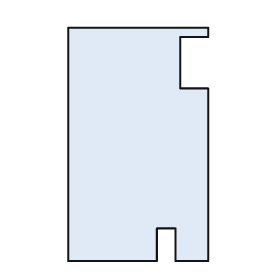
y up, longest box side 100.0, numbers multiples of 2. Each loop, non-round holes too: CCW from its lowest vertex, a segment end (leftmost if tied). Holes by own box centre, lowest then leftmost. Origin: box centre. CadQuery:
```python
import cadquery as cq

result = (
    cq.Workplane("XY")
    .moveTo(-30.0, -50.0)
    .lineTo(8.0, -50.0)
    .lineTo(8.0, -36.0)
    .lineTo(16.0, -36.0)
    .lineTo(16.0, -50.0)
    .lineTo(30.0, -50.0)
    .lineTo(30.0, 24.0)
    .lineTo(18.0, 24.0)
    .lineTo(18.0, 46.0)
    .lineTo(30.0, 46.0)
    .lineTo(30.0, 50.0)
    .lineTo(-30.0, 50.0)
    .close()
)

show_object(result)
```